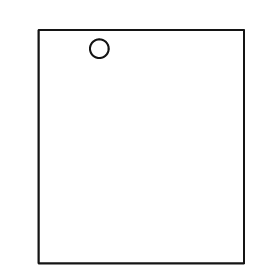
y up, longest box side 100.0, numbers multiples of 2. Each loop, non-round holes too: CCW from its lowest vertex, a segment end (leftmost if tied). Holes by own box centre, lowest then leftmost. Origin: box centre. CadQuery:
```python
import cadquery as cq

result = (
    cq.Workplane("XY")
    .moveTo(-44.0, -50.0)
    .lineTo(44.0, -50.0)
    .lineTo(44.0, 50.0)
    .lineTo(-44.0, 50.0)
    .close()
    .moveTo(-18.0, 42.0)
    .circle(4.0)
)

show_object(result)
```